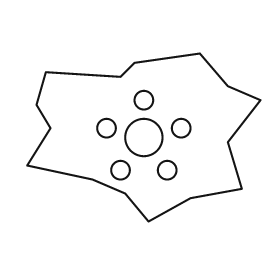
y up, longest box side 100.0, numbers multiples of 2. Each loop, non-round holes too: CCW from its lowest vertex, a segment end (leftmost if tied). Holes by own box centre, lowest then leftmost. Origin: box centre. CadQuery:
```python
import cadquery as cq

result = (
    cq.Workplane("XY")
    .moveTo(2.0, -36.0)
    .lineTo(20.0, -26.0)
    .lineTo(42.0, -22.0)
    .lineTo(36.0, -2.0)
    .lineTo(50.0, 16.0)
    .lineTo(36.0, 22.0)
    .lineTo(24.0, 36.0)
    .lineTo(-4.0, 32.0)
    .lineTo(-10.0, 26.0)
    .lineTo(-42.0, 28.0)
    .lineTo(-46.0, 14.0)
    .lineTo(-40.0, 4.0)
    .lineTo(-50.0, -12.0)
    .lineTo(-22.0, -18.0)
    .lineTo(-8.0, -24.0)
    .close()
    .moveTo(-10.0, -14.0)
    .circle(4.0)
    .moveTo(10.0, -14.0)
    .circle(4.0)
    .moveTo(0.0, 0.0)
    .circle(8.0)
    .moveTo(-16.0, 4.0)
    .circle(4.0)
    .moveTo(16.0, 4.0)
    .circle(4.0)
    .moveTo(0.0, 16.0)
    .circle(4.0)
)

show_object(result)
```